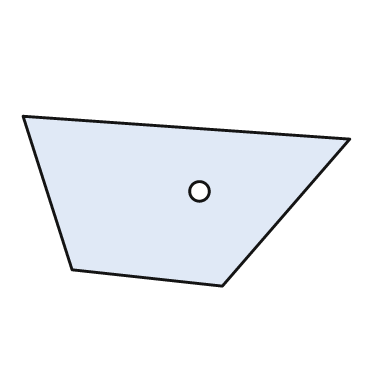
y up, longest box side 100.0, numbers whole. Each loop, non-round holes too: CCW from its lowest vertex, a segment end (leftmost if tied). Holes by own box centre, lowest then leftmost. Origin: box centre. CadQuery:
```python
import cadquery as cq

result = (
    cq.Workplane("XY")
    .moveTo(11.0, -26.0)
    .lineTo(50.0, 19.0)
    .lineTo(-50.0, 26.0)
    .lineTo(-35.0, -21.0)
    .close()
    .moveTo(4.0, 3.0)
    .circle(3.0)
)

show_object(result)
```